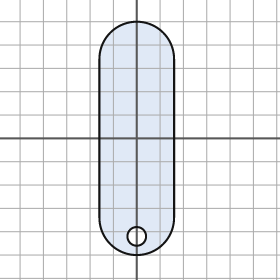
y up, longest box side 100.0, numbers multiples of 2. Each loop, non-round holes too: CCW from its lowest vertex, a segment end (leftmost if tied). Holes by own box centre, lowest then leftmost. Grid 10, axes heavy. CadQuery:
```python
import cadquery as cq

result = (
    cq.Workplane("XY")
    .moveTo(-16.0, -34.0)
    .threePointArc((0.0, -50.0), (16.0, -34.0))
    .lineTo(16.0, 34.0)
    .threePointArc((0.0, 50.0), (-16.0, 34.0))
    .close()
    .moveTo(0.0, -42.0)
    .circle(4.0)
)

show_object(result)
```